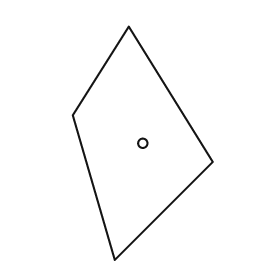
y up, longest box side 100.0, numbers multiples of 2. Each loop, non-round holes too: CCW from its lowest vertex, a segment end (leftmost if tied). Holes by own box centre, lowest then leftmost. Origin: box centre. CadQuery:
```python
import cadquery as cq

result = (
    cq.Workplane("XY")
    .moveTo(-12.0, -50.0)
    .lineTo(30.0, -8.0)
    .lineTo(-6.0, 50.0)
    .lineTo(-30.0, 12.0)
    .close()
    .moveTo(0.0, 0.0)
    .circle(2.0)
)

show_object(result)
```